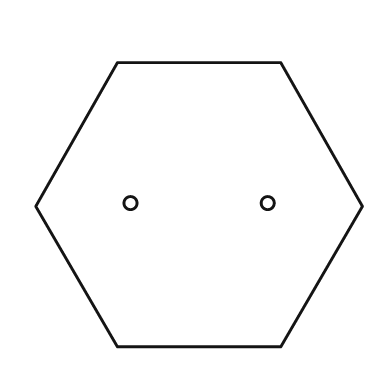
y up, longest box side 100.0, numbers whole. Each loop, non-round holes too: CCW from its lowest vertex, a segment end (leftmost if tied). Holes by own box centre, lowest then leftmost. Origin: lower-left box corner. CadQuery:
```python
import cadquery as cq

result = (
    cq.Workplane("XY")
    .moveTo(25.0, 0.0)
    .lineTo(75.0, 0.0)
    .lineTo(100.0, 43.0)
    .lineTo(75.0, 87.0)
    .lineTo(25.0, 87.0)
    .lineTo(0.0, 43.0)
    .close()
    .moveTo(29.0, 44.0)
    .circle(2.0)
    .moveTo(71.0, 44.0)
    .circle(2.0)
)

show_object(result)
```